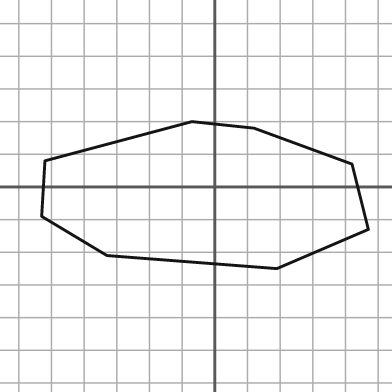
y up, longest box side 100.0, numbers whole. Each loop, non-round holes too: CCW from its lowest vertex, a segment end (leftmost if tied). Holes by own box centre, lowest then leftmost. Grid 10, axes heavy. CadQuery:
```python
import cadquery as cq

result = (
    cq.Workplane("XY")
    .moveTo(19.0, -25.0)
    .lineTo(47.0, -13.0)
    .lineTo(42.0, 7.0)
    .lineTo(12.0, 18.0)
    .lineTo(-7.0, 20.0)
    .lineTo(-52.0, 8.0)
    .lineTo(-53.0, -9.0)
    .lineTo(-33.0, -21.0)
    .close()
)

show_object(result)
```